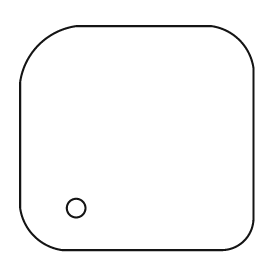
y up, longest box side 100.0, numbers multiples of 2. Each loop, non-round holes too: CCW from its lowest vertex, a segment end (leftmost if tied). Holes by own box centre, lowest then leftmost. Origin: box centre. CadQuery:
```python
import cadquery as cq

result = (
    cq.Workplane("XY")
    .moveTo(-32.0, -48.0)
    .lineTo(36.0, -48.0)
    .threePointArc((46.0, -44.0), (50.0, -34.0))
    .lineTo(50.0, 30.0)
    .threePointArc((44.0, 42.0), (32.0, 48.0))
    .lineTo(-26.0, 48.0)
    .threePointArc((-42.0, 40.0), (-50.0, 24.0))
    .lineTo(-50.0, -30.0)
    .threePointArc((-44.0, -42.0), (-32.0, -48.0))
    .close()
    .moveTo(-26.0, -30.0)
    .circle(4.0)
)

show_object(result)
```